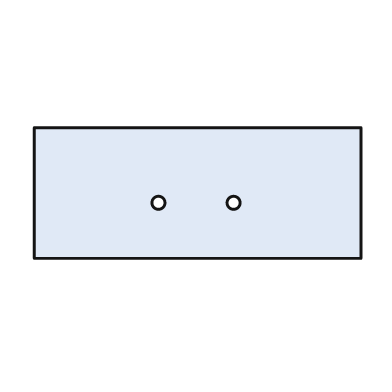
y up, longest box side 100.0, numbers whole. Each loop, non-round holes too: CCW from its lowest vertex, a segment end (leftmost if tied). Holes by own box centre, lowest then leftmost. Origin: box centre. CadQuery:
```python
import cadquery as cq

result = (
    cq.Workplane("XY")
    .moveTo(-50.0, -20.0)
    .lineTo(50.0, -20.0)
    .lineTo(50.0, 20.0)
    .lineTo(-50.0, 20.0)
    .close()
    .moveTo(-12.0, -3.0)
    .circle(2.0)
    .moveTo(11.0, -3.0)
    .circle(2.0)
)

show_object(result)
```